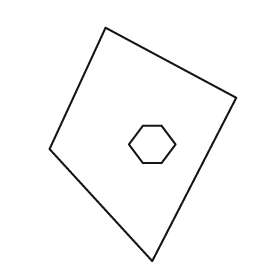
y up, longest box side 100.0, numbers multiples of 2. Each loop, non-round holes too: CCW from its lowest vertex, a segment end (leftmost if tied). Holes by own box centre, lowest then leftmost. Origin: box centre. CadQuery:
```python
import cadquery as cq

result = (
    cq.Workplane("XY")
    .moveTo(4.0, -50.0)
    .lineTo(40.0, 20.0)
    .lineTo(-16.0, 50.0)
    .lineTo(-40.0, -2.0)
    .close()
    .moveTo(0.0, -8.0)
    .lineTo(8.0, -8.0)
    .lineTo(14.0, 0.0)
    .lineTo(8.0, 8.0)
    .lineTo(0.0, 8.0)
    .lineTo(-6.0, 0.0)
    .close()
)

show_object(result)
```